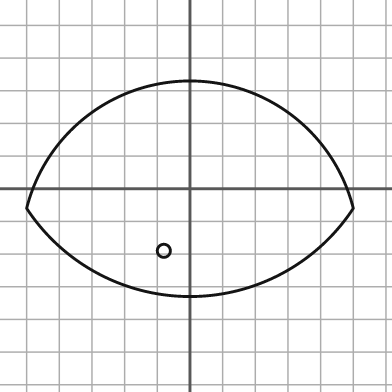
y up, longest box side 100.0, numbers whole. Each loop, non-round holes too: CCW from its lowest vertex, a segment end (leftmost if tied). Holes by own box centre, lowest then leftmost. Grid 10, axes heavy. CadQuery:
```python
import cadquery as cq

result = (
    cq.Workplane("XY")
    .moveTo(-50.0, -6.0)
    .threePointArc((0.0, -33.0), (50.0, -6.0))
    .threePointArc((0.0, 33.0), (-50.0, -6.0))
    .close()
    .moveTo(-8.0, -19.0)
    .circle(2.0)
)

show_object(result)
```